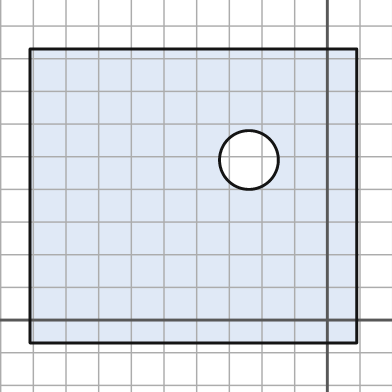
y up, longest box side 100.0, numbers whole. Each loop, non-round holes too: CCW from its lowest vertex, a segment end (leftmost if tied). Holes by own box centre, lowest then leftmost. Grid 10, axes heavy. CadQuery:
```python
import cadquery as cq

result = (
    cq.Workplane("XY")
    .moveTo(-91.0, -7.0)
    .lineTo(9.0, -7.0)
    .lineTo(9.0, 83.0)
    .lineTo(-91.0, 83.0)
    .close()
    .moveTo(-24.0, 49.0)
    .circle(9.0)
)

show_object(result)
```